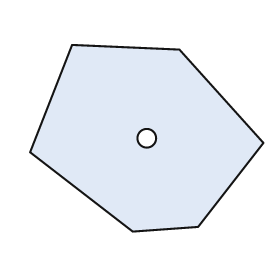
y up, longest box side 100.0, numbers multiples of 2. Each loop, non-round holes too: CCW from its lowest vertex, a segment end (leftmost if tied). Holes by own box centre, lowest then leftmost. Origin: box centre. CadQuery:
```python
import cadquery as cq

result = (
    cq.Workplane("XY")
    .moveTo(-6.0, -40.0)
    .lineTo(22.0, -38.0)
    .lineTo(50.0, -2.0)
    .lineTo(14.0, 38.0)
    .lineTo(-32.0, 40.0)
    .lineTo(-50.0, -6.0)
    .close()
    .moveTo(0.0, 0.0)
    .circle(4.0)
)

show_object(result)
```